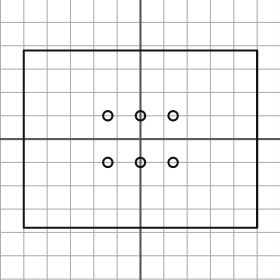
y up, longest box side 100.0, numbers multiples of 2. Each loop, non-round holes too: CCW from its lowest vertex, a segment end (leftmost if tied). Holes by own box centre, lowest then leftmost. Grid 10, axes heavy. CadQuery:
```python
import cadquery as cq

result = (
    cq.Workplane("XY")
    .moveTo(-50.0, -38.0)
    .lineTo(50.0, -38.0)
    .lineTo(50.0, 38.0)
    .lineTo(-50.0, 38.0)
    .close()
    .moveTo(-14.0, -10.0)
    .circle(2.0)
    .moveTo(0.0, -10.0)
    .circle(2.0)
    .moveTo(14.0, -10.0)
    .circle(2.0)
    .moveTo(-14.0, 10.0)
    .circle(2.0)
    .moveTo(0.0, 10.0)
    .circle(2.0)
    .moveTo(14.0, 10.0)
    .circle(2.0)
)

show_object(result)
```